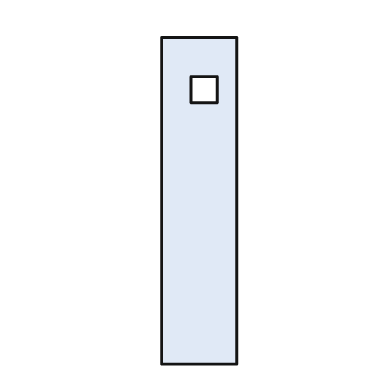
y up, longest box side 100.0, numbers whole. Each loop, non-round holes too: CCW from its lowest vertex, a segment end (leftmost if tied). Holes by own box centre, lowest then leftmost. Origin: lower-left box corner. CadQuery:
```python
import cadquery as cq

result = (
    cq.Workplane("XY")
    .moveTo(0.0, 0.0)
    .lineTo(23.0, 0.0)
    .lineTo(23.0, 100.0)
    .lineTo(0.0, 100.0)
    .close()
    .moveTo(9.0, 80.0)
    .lineTo(17.0, 80.0)
    .lineTo(17.0, 88.0)
    .lineTo(9.0, 88.0)
    .close()
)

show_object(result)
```